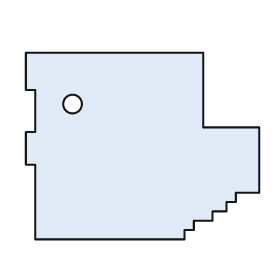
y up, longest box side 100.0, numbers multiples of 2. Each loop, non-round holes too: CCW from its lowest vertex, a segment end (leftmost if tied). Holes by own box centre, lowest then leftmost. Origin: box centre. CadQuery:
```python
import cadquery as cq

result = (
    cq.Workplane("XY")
    .moveTo(-46.0, -40.0)
    .lineTo(18.0, -40.0)
    .lineTo(18.0, -36.0)
    .lineTo(22.0, -36.0)
    .lineTo(22.0, -32.0)
    .lineTo(30.0, -32.0)
    .lineTo(30.0, -28.0)
    .lineTo(36.0, -28.0)
    .lineTo(36.0, -24.0)
    .lineTo(40.0, -24.0)
    .lineTo(40.0, -20.0)
    .lineTo(50.0, -20.0)
    .lineTo(50.0, 8.0)
    .lineTo(26.0, 8.0)
    .lineTo(26.0, 40.0)
    .lineTo(-50.0, 40.0)
    .lineTo(-50.0, 24.0)
    .lineTo(-46.0, 24.0)
    .lineTo(-46.0, 6.0)
    .lineTo(-50.0, 6.0)
    .lineTo(-50.0, -8.0)
    .lineTo(-46.0, -8.0)
    .close()
    .moveTo(-30.0, 18.0)
    .circle(4.0)
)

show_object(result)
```